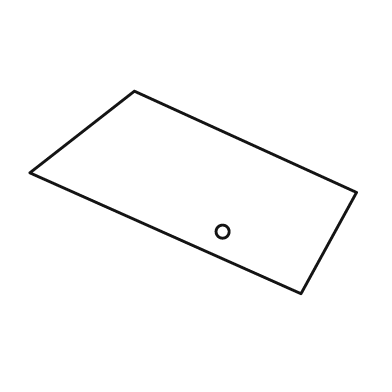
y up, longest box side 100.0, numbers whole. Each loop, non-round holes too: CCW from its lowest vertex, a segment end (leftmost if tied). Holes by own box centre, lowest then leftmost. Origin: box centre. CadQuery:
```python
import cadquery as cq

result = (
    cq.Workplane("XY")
    .moveTo(33.0, -31.0)
    .lineTo(50.0, 0.0)
    .lineTo(-18.0, 31.0)
    .lineTo(-50.0, 6.0)
    .close()
    .moveTo(9.0, -12.0)
    .circle(2.0)
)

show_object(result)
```